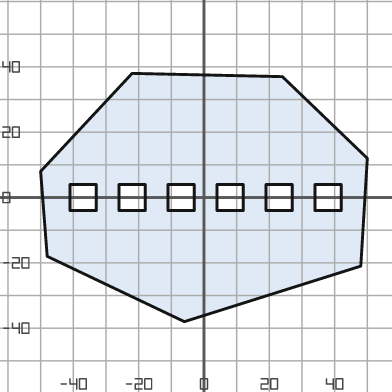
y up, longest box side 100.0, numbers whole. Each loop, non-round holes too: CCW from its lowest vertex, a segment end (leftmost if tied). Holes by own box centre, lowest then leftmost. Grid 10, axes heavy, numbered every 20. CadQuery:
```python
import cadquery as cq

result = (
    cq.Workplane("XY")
    .moveTo(-6.0, -38.0)
    .lineTo(48.0, -21.0)
    .lineTo(50.0, 12.0)
    .lineTo(24.0, 37.0)
    .lineTo(-22.0, 38.0)
    .lineTo(-50.0, 8.0)
    .lineTo(-48.0, -18.0)
    .close()
    .moveTo(-41.0, -4.0)
    .lineTo(-33.0, -4.0)
    .lineTo(-33.0, 4.0)
    .lineTo(-41.0, 4.0)
    .close()
    .moveTo(-26.0, -4.0)
    .lineTo(-18.0, -4.0)
    .lineTo(-18.0, 4.0)
    .lineTo(-26.0, 4.0)
    .close()
    .moveTo(-11.0, -4.0)
    .lineTo(-3.0, -4.0)
    .lineTo(-3.0, 4.0)
    .lineTo(-11.0, 4.0)
    .close()
    .moveTo(4.0, -4.0)
    .lineTo(12.0, -4.0)
    .lineTo(12.0, 4.0)
    .lineTo(4.0, 4.0)
    .close()
    .moveTo(19.0, -4.0)
    .lineTo(27.0, -4.0)
    .lineTo(27.0, 4.0)
    .lineTo(19.0, 4.0)
    .close()
    .moveTo(34.0, -4.0)
    .lineTo(42.0, -4.0)
    .lineTo(42.0, 4.0)
    .lineTo(34.0, 4.0)
    .close()
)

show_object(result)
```